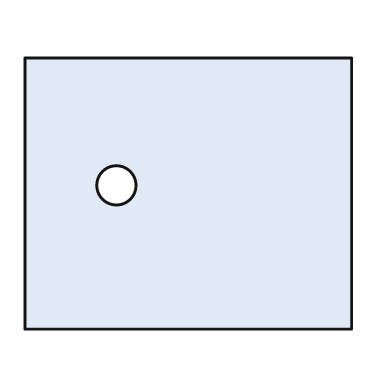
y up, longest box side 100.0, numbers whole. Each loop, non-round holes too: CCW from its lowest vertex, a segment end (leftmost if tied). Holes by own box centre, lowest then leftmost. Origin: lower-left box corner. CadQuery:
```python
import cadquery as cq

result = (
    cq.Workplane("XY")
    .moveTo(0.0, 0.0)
    .lineTo(100.0, 0.0)
    .lineTo(100.0, 83.0)
    .lineTo(0.0, 83.0)
    .close()
    .moveTo(28.0, 44.0)
    .circle(6.0)
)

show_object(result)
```